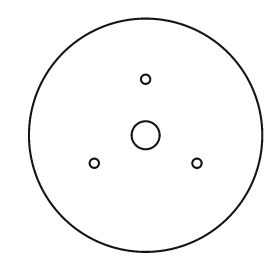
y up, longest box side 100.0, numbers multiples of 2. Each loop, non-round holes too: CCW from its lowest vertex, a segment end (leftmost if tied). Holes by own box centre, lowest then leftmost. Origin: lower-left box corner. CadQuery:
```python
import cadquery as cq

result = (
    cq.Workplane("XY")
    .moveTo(50.0, 50.0)
    .circle(50.0)
    .moveTo(28.0, 38.0)
    .circle(2.0)
    .moveTo(72.0, 38.0)
    .circle(2.0)
    .moveTo(50.0, 50.0)
    .circle(6.0)
    .moveTo(50.0, 74.0)
    .circle(2.0)
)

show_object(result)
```